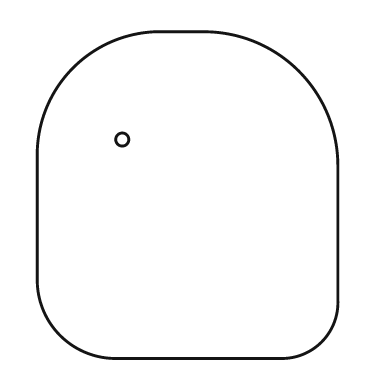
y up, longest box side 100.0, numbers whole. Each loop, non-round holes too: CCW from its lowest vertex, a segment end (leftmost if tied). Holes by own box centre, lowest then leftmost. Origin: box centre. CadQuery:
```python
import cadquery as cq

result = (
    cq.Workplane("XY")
    .moveTo(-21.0, -50.0)
    .lineTo(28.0, -50.0)
    .threePointArc((41.0, -45.0), (46.0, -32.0))
    .lineTo(46.0, 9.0)
    .threePointArc((34.0, 38.0), (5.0, 50.0))
    .lineTo(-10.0, 50.0)
    .threePointArc((-35.0, 39.0), (-46.0, 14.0))
    .lineTo(-46.0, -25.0)
    .threePointArc((-39.0, -43.0), (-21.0, -50.0))
    .close()
    .moveTo(-20.0, 17.0)
    .circle(2.0)
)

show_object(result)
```